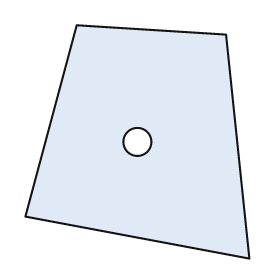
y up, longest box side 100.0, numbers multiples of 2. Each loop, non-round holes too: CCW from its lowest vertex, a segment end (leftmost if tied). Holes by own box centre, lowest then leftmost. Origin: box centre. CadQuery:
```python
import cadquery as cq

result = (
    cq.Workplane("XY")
    .moveTo(48.0, -50.0)
    .lineTo(38.0, 46.0)
    .lineTo(-26.0, 50.0)
    .lineTo(-48.0, -32.0)
    .close()
    .moveTo(0.0, 0.0)
    .circle(6.0)
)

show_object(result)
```